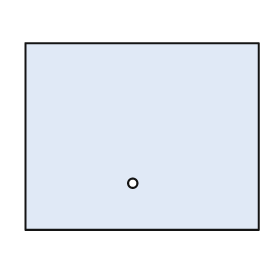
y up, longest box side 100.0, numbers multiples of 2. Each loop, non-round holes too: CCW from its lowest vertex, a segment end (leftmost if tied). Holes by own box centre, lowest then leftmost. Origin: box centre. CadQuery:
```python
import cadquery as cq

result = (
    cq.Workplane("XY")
    .moveTo(-50.0, -40.0)
    .lineTo(50.0, -40.0)
    .lineTo(50.0, 40.0)
    .lineTo(-50.0, 40.0)
    .close()
    .moveTo(-4.0, -20.0)
    .circle(2.0)
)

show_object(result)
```